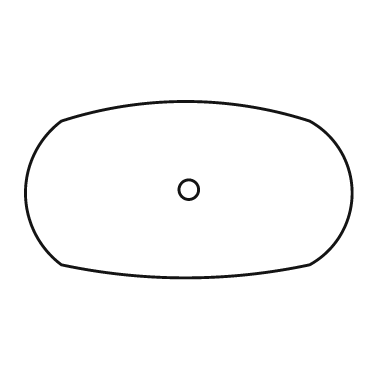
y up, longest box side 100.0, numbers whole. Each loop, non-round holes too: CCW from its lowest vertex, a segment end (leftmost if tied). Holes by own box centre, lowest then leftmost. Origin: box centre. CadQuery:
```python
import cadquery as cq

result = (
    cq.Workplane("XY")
    .moveTo(-39.0, -23.0)
    .threePointArc((-1.0, -27.0), (37.0, -23.0))
    .threePointArc((50.0, -1.0), (37.0, 21.0))
    .threePointArc((-1.0, 27.0), (-39.0, 21.0))
    .threePointArc((-50.0, -1.0), (-39.0, -23.0))
    .close()
    .moveTo(0.0, 0.0)
    .circle(3.0)
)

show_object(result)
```